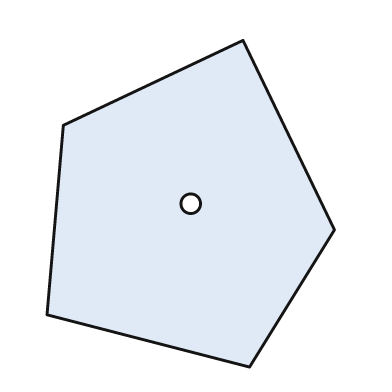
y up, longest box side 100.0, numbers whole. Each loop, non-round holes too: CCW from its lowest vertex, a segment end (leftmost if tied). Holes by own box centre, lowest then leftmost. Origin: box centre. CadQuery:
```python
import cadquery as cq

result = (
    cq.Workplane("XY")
    .moveTo(18.0, -50.0)
    .lineTo(44.0, -8.0)
    .lineTo(16.0, 50.0)
    .lineTo(-39.0, 24.0)
    .lineTo(-44.0, -34.0)
    .close()
    .moveTo(0.0, 0.0)
    .circle(3.0)
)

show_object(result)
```